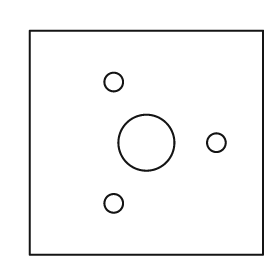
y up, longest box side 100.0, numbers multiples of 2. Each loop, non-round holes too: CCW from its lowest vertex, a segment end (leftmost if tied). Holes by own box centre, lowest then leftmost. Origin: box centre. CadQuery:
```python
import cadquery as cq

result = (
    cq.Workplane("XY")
    .moveTo(-50.0, -48.0)
    .lineTo(50.0, -48.0)
    .lineTo(50.0, 48.0)
    .lineTo(-50.0, 48.0)
    .close()
    .moveTo(-14.0, -26.0)
    .circle(4.0)
    .moveTo(0.0, 0.0)
    .circle(12.0)
    .moveTo(30.0, 0.0)
    .circle(4.0)
    .moveTo(-14.0, 26.0)
    .circle(4.0)
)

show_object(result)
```